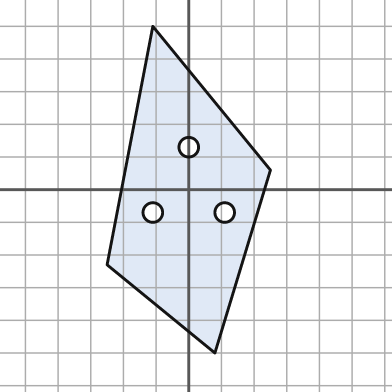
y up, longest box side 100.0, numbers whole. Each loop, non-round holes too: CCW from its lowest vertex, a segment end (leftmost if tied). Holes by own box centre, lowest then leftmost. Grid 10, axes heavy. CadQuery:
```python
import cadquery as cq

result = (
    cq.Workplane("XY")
    .moveTo(8.0, -50.0)
    .lineTo(25.0, 6.0)
    .lineTo(-11.0, 50.0)
    .lineTo(-25.0, -23.0)
    .close()
    .moveTo(-11.0, -7.0)
    .circle(3.0)
    .moveTo(11.0, -7.0)
    .circle(3.0)
    .moveTo(0.0, 13.0)
    .circle(3.0)
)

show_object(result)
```